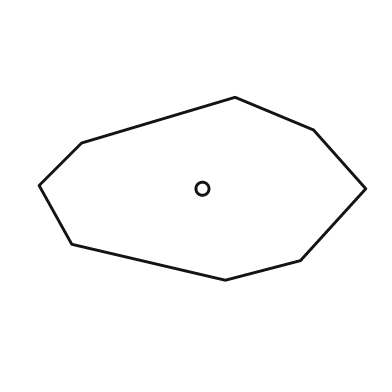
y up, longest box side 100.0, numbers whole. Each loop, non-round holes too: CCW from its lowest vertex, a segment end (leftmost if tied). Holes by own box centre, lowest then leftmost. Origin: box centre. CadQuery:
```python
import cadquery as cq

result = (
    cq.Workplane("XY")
    .moveTo(7.0, -28.0)
    .lineTo(30.0, -22.0)
    .lineTo(50.0, 0.0)
    .lineTo(34.0, 18.0)
    .lineTo(10.0, 28.0)
    .lineTo(-37.0, 14.0)
    .lineTo(-50.0, 1.0)
    .lineTo(-40.0, -17.0)
    .close()
    .moveTo(0.0, 0.0)
    .circle(2.0)
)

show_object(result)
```